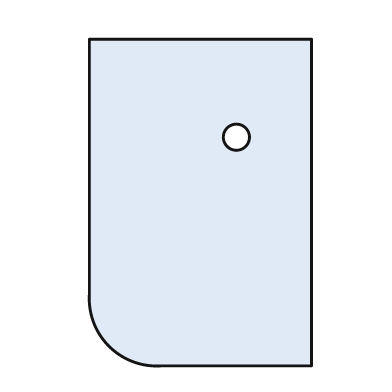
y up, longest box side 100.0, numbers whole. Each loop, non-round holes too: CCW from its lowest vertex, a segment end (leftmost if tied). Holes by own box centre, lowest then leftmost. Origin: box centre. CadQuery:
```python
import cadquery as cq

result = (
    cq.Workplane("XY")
    .moveTo(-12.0, -50.0)
    .lineTo(34.0, -50.0)
    .lineTo(34.0, 50.0)
    .lineTo(-34.0, 50.0)
    .lineTo(-34.0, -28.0)
    .threePointArc((-28.0, -44.0), (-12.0, -50.0))
    .close()
    .moveTo(11.0, 20.0)
    .circle(4.0)
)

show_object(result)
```